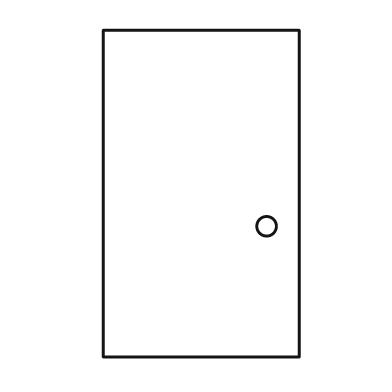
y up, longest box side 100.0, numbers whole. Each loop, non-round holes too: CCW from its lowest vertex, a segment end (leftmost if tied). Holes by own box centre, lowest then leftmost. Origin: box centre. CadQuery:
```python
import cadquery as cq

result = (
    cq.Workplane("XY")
    .moveTo(-30.0, -50.0)
    .lineTo(30.0, -50.0)
    .lineTo(30.0, 50.0)
    .lineTo(-30.0, 50.0)
    .close()
    .moveTo(20.0, -10.0)
    .circle(3.0)
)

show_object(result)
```